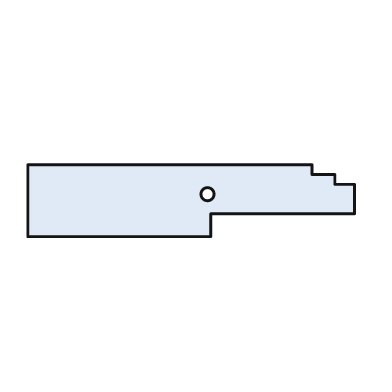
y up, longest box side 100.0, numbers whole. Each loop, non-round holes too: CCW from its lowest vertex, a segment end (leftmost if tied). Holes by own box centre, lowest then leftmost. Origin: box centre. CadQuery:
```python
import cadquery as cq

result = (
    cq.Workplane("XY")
    .moveTo(-50.0, -11.0)
    .lineTo(6.0, -11.0)
    .lineTo(6.0, -4.0)
    .lineTo(50.0, -4.0)
    .lineTo(50.0, 5.0)
    .lineTo(44.0, 5.0)
    .lineTo(44.0, 8.0)
    .lineTo(37.0, 8.0)
    .lineTo(37.0, 11.0)
    .lineTo(-50.0, 11.0)
    .close()
    .moveTo(5.0, 2.0)
    .circle(2.0)
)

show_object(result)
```